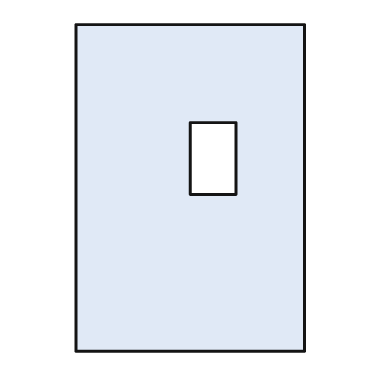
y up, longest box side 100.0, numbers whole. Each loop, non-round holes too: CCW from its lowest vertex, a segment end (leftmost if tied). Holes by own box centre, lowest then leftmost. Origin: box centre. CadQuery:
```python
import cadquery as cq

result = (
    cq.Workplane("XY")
    .moveTo(-35.0, -50.0)
    .lineTo(35.0, -50.0)
    .lineTo(35.0, 50.0)
    .lineTo(-35.0, 50.0)
    .close()
    .moveTo(0.0, -2.0)
    .lineTo(14.0, -2.0)
    .lineTo(14.0, 20.0)
    .lineTo(0.0, 20.0)
    .close()
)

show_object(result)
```